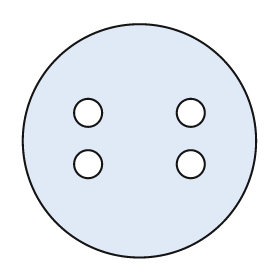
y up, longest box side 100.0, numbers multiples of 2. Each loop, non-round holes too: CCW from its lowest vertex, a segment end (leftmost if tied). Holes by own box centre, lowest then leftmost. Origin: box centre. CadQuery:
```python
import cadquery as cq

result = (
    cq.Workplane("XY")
    .moveTo(0.0, 0.0)
    .circle(50.0)
    .moveTo(-22.0, -10.0)
    .circle(6.0)
    .moveTo(22.0, -10.0)
    .circle(6.0)
    .moveTo(-22.0, 12.0)
    .circle(6.0)
    .moveTo(22.0, 12.0)
    .circle(6.0)
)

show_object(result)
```